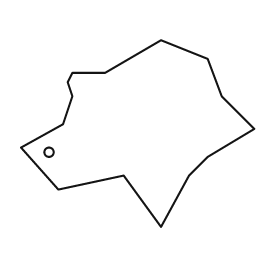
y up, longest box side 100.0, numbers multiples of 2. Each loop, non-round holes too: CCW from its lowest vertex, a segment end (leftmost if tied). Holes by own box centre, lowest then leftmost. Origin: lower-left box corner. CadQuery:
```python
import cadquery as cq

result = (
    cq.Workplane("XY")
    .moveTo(60.0, 0.0)
    .lineTo(72.0, 22.0)
    .lineTo(80.0, 30.0)
    .lineTo(100.0, 42.0)
    .lineTo(86.0, 56.0)
    .lineTo(80.0, 72.0)
    .lineTo(60.0, 80.0)
    .lineTo(36.0, 66.0)
    .lineTo(22.0, 66.0)
    .lineTo(20.0, 62.0)
    .lineTo(22.0, 56.0)
    .lineTo(18.0, 44.0)
    .lineTo(0.0, 34.0)
    .lineTo(16.0, 16.0)
    .lineTo(44.0, 22.0)
    .close()
    .moveTo(12.0, 32.0)
    .circle(2.0)
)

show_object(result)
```